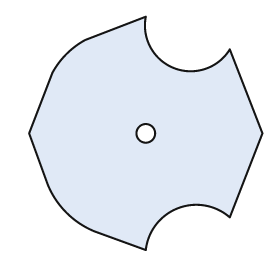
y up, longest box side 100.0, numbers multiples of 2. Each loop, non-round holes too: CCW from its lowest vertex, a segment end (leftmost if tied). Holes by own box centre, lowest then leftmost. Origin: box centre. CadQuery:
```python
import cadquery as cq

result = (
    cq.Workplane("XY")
    .moveTo(0.0, -50.0)
    .threePointArc((14.0, -32.0), (36.0, -36.0))
    .lineTo(50.0, 0.0)
    .lineTo(36.0, 36.0)
    .threePointArc((12.0, 28.0), (0.0, 50.0))
    .lineTo(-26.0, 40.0)
    .threePointArc((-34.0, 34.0), (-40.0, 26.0))
    .lineTo(-50.0, 0.0)
    .lineTo(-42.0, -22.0)
    .threePointArc((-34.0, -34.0), (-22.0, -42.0))
    .close()
    .moveTo(0.0, 0.0)
    .circle(4.0)
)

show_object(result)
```